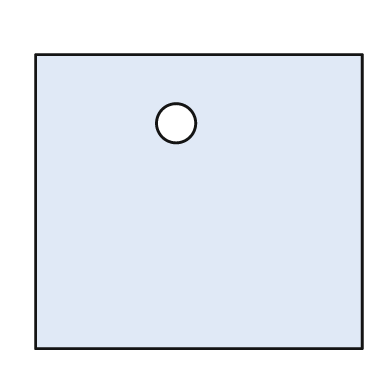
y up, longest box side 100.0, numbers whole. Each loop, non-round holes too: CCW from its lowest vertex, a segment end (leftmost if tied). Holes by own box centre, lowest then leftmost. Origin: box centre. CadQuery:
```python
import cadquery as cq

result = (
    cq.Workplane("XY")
    .moveTo(-50.0, -45.0)
    .lineTo(50.0, -45.0)
    .lineTo(50.0, 45.0)
    .lineTo(-50.0, 45.0)
    .close()
    .moveTo(-7.0, 24.0)
    .circle(6.0)
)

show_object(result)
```